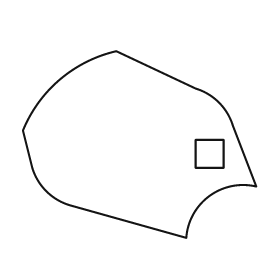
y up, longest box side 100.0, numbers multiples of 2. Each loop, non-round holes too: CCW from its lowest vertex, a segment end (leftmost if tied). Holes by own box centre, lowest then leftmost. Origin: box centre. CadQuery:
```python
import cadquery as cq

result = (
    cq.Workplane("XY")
    .moveTo(20.0, -40.0)
    .threePointArc((30.0, -22.0), (50.0, -18.0))
    .lineTo(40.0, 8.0)
    .threePointArc((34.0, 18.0), (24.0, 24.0))
    .lineTo(-10.0, 40.0)
    .threePointArc((-34.0, 28.0), (-50.0, 6.0))
    .lineTo(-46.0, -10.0)
    .threePointArc((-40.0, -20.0), (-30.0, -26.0))
    .close()
    .moveTo(24.0, -10.0)
    .lineTo(36.0, -10.0)
    .lineTo(36.0, 2.0)
    .lineTo(24.0, 2.0)
    .close()
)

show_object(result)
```